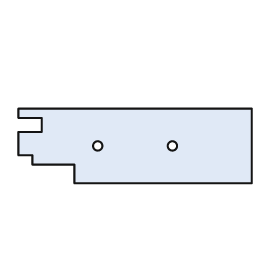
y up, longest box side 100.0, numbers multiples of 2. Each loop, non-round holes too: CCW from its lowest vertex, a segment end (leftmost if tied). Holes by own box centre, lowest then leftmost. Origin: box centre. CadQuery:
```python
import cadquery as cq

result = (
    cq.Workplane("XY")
    .moveTo(-26.0, -16.0)
    .lineTo(50.0, -16.0)
    .lineTo(50.0, 16.0)
    .lineTo(-50.0, 16.0)
    .lineTo(-50.0, 12.0)
    .lineTo(-40.0, 12.0)
    .lineTo(-40.0, 6.0)
    .lineTo(-50.0, 6.0)
    .lineTo(-50.0, -4.0)
    .lineTo(-44.0, -4.0)
    .lineTo(-44.0, -8.0)
    .lineTo(-26.0, -8.0)
    .close()
    .moveTo(-16.0, 0.0)
    .circle(2.0)
    .moveTo(16.0, 0.0)
    .circle(2.0)
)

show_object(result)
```